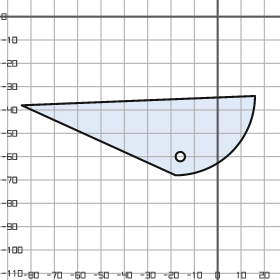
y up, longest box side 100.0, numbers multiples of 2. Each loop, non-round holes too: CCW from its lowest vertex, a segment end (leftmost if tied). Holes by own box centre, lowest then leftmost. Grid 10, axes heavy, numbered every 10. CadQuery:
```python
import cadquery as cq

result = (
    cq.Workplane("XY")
    .moveTo(-18.0, -68.0)
    .threePointArc((6.0, -58.0), (16.0, -34.0))
    .lineTo(-84.0, -38.0)
    .close()
    .moveTo(-16.0, -60.0)
    .circle(2.0)
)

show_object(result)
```